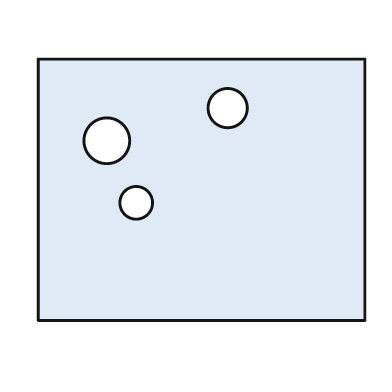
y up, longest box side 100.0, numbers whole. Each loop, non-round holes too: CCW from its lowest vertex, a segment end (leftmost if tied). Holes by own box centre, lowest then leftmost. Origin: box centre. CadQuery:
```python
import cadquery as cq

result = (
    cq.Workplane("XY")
    .moveTo(-50.0, -40.0)
    .lineTo(50.0, -40.0)
    .lineTo(50.0, 40.0)
    .lineTo(-50.0, 40.0)
    .close()
    .moveTo(-20.0, -4.0)
    .circle(5.0)
    .moveTo(-29.0, 15.0)
    .circle(7.0)
    .moveTo(8.0, 25.0)
    .circle(6.0)
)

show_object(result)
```